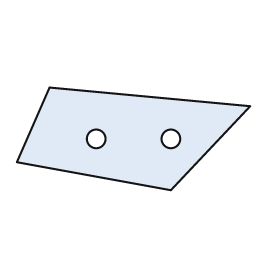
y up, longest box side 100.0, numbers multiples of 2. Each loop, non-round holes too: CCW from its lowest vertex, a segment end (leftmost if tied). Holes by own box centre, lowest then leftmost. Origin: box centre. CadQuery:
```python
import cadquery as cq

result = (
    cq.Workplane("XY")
    .moveTo(16.0, -22.0)
    .lineTo(50.0, 14.0)
    .lineTo(-36.0, 22.0)
    .lineTo(-50.0, -10.0)
    .close()
    .moveTo(-16.0, 0.0)
    .circle(4.0)
    .moveTo(16.0, 0.0)
    .circle(4.0)
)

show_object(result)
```